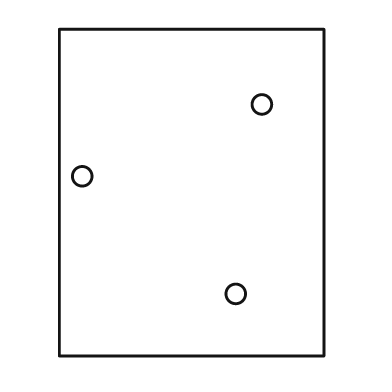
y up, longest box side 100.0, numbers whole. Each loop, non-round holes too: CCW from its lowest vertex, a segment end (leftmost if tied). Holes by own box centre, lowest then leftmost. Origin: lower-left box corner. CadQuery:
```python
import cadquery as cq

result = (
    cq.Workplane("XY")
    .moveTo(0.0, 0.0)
    .lineTo(81.0, 0.0)
    .lineTo(81.0, 100.0)
    .lineTo(0.0, 100.0)
    .close()
    .moveTo(54.0, 19.0)
    .circle(3.0)
    .moveTo(7.0, 55.0)
    .circle(3.0)
    .moveTo(62.0, 77.0)
    .circle(3.0)
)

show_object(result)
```